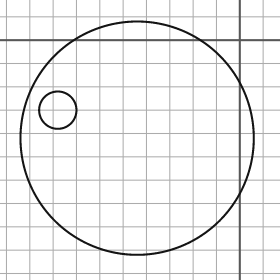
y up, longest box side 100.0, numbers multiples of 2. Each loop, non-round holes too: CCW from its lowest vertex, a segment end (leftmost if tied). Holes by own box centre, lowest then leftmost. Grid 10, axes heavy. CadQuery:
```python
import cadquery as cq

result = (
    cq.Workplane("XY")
    .moveTo(-44.0, -42.0)
    .circle(50.0)
    .moveTo(-78.0, -30.0)
    .circle(8.0)
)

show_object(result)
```